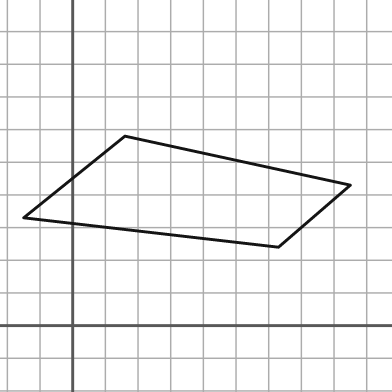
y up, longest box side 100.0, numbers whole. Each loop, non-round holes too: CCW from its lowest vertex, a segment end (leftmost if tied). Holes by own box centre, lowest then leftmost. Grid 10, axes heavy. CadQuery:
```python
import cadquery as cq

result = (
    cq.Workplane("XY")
    .moveTo(63.0, 24.0)
    .lineTo(85.0, 43.0)
    .lineTo(16.0, 58.0)
    .lineTo(-15.0, 33.0)
    .close()
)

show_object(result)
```